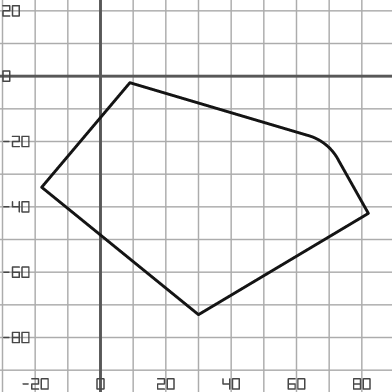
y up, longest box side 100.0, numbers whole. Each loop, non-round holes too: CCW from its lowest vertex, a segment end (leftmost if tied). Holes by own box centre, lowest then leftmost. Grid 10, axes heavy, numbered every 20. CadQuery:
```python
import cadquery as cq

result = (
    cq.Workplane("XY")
    .moveTo(30.0, -73.0)
    .lineTo(82.0, -42.0)
    .lineTo(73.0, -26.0)
    .threePointArc((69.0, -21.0), (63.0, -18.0))
    .lineTo(9.0, -2.0)
    .lineTo(-18.0, -34.0)
    .close()
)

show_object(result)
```